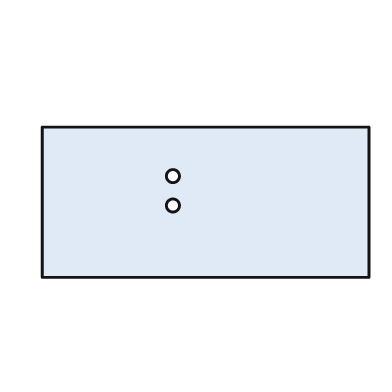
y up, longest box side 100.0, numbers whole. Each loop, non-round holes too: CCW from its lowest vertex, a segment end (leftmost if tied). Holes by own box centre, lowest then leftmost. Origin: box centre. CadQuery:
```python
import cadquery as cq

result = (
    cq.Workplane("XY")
    .moveTo(-50.0, -23.0)
    .lineTo(50.0, -23.0)
    .lineTo(50.0, 23.0)
    .lineTo(-50.0, 23.0)
    .close()
    .moveTo(-10.0, -1.0)
    .circle(2.0)
    .moveTo(-10.0, 8.0)
    .circle(2.0)
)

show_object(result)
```